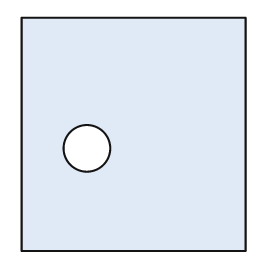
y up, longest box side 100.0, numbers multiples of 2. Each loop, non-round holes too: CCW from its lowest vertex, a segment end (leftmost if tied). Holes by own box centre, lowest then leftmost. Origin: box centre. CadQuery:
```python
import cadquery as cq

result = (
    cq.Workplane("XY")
    .moveTo(-48.0, -50.0)
    .lineTo(48.0, -50.0)
    .lineTo(48.0, 50.0)
    .lineTo(-48.0, 50.0)
    .close()
    .moveTo(-20.0, -6.0)
    .circle(10.0)
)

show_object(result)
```